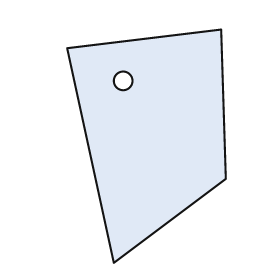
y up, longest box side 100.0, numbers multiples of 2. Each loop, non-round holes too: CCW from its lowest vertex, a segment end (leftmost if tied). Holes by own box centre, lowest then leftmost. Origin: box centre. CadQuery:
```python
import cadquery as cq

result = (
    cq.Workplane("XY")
    .moveTo(-14.0, -50.0)
    .lineTo(34.0, -14.0)
    .lineTo(32.0, 50.0)
    .lineTo(-34.0, 42.0)
    .close()
    .moveTo(-10.0, 28.0)
    .circle(4.0)
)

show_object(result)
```